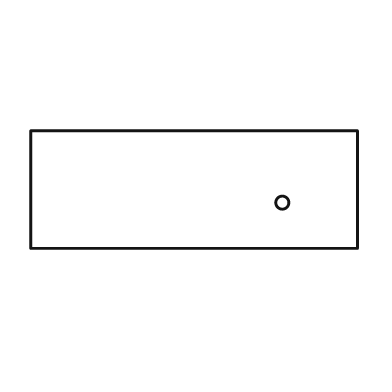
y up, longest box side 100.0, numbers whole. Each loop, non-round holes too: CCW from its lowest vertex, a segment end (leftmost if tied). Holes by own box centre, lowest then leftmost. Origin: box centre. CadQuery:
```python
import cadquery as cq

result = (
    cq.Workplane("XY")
    .moveTo(-50.0, -18.0)
    .lineTo(50.0, -18.0)
    .lineTo(50.0, 18.0)
    .lineTo(-50.0, 18.0)
    .close()
    .moveTo(27.0, -4.0)
    .circle(2.0)
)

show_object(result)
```